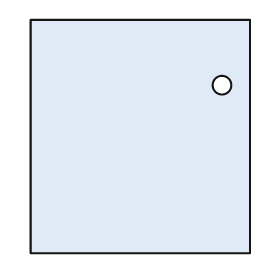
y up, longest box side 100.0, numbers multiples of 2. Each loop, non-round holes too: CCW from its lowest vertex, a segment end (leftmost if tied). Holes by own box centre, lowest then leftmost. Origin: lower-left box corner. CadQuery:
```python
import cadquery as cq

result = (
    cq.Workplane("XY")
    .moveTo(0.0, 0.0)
    .lineTo(94.0, 0.0)
    .lineTo(94.0, 100.0)
    .lineTo(0.0, 100.0)
    .close()
    .moveTo(82.0, 72.0)
    .circle(4.0)
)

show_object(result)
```